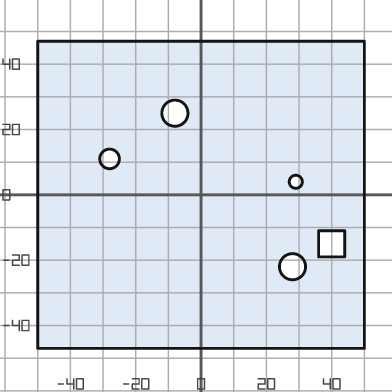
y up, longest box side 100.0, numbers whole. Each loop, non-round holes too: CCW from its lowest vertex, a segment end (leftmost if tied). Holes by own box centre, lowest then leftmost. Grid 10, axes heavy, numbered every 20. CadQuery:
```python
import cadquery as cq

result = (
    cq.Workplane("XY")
    .moveTo(-50.0, -47.0)
    .lineTo(50.0, -47.0)
    .lineTo(50.0, 47.0)
    .lineTo(-50.0, 47.0)
    .close()
    .moveTo(28.0, -22.0)
    .circle(4.0)
    .moveTo(36.0, -19.0)
    .lineTo(44.0, -19.0)
    .lineTo(44.0, -11.0)
    .lineTo(36.0, -11.0)
    .close()
    .moveTo(29.0, 4.0)
    .circle(2.0)
    .moveTo(-28.0, 11.0)
    .circle(3.0)
    .moveTo(-8.0, 25.0)
    .circle(4.0)
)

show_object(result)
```